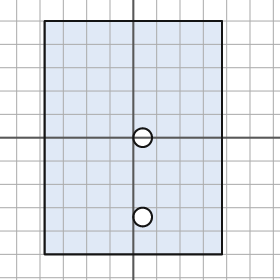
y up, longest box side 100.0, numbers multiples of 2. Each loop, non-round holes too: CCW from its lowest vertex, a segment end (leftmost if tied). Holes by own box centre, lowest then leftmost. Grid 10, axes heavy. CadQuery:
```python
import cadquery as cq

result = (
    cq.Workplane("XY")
    .moveTo(-38.0, -50.0)
    .lineTo(38.0, -50.0)
    .lineTo(38.0, 50.0)
    .lineTo(-38.0, 50.0)
    .close()
    .moveTo(4.0, -34.0)
    .circle(4.0)
    .moveTo(4.0, 0.0)
    .circle(4.0)
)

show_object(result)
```